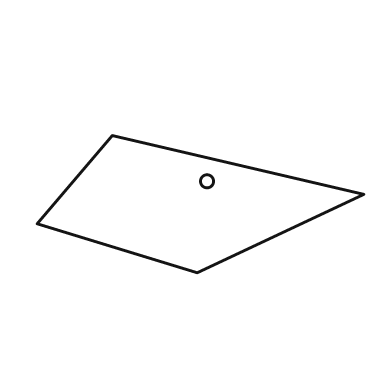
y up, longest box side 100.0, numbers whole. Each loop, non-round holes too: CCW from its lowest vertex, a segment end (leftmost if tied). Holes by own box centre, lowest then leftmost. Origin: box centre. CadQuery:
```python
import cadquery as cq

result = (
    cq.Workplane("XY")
    .moveTo(-1.0, -21.0)
    .lineTo(50.0, 3.0)
    .lineTo(-27.0, 21.0)
    .lineTo(-50.0, -6.0)
    .close()
    .moveTo(2.0, 7.0)
    .circle(2.0)
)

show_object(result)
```